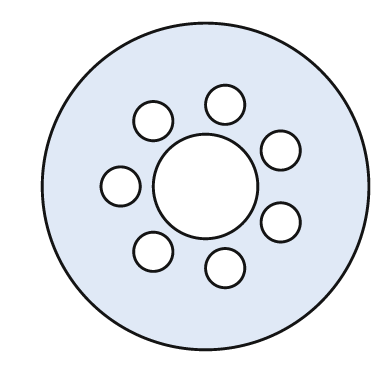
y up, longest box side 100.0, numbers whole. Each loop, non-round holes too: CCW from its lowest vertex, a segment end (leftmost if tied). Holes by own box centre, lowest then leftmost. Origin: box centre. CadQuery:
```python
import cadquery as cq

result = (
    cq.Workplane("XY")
    .moveTo(0.0, 0.0)
    .circle(50.0)
    .moveTo(6.0, -25.0)
    .circle(6.0)
    .moveTo(-16.0, -20.0)
    .circle(6.0)
    .moveTo(23.0, -11.0)
    .circle(6.0)
    .moveTo(-26.0, 0.0)
    .circle(6.0)
    .moveTo(0.0, 0.0)
    .circle(16.0)
    .moveTo(23.0, 11.0)
    .circle(6.0)
    .moveTo(-16.0, 20.0)
    .circle(6.0)
    .moveTo(6.0, 25.0)
    .circle(6.0)
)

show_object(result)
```